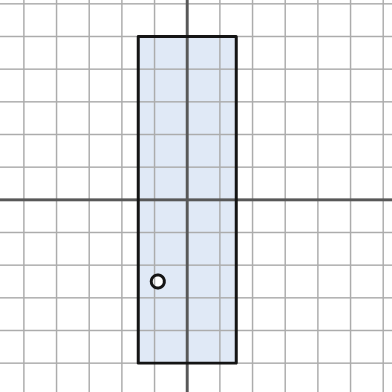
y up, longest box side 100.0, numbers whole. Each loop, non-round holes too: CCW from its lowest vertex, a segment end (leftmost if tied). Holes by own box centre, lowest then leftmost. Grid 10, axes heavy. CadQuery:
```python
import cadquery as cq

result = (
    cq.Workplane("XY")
    .moveTo(-15.0, -50.0)
    .lineTo(15.0, -50.0)
    .lineTo(15.0, 50.0)
    .lineTo(-15.0, 50.0)
    .close()
    .moveTo(-9.0, -25.0)
    .circle(2.0)
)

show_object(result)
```